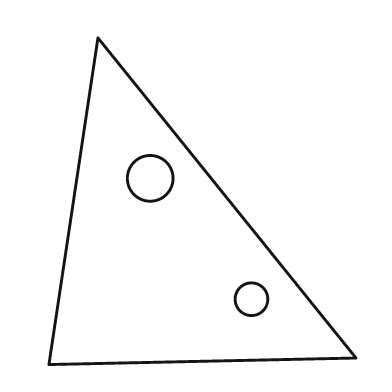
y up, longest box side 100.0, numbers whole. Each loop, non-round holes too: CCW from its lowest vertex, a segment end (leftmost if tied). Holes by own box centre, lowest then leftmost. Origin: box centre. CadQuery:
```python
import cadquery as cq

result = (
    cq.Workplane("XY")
    .moveTo(-47.0, -50.0)
    .lineTo(47.0, -48.0)
    .lineTo(-32.0, 50.0)
    .close()
    .moveTo(15.0, -30.0)
    .circle(5.0)
    .moveTo(-16.0, 7.0)
    .circle(7.0)
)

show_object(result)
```